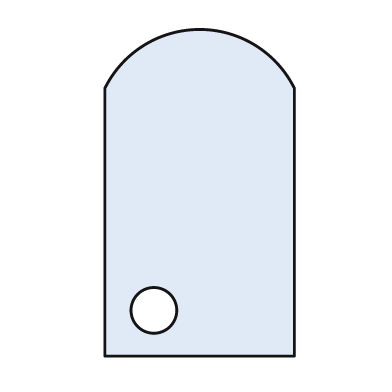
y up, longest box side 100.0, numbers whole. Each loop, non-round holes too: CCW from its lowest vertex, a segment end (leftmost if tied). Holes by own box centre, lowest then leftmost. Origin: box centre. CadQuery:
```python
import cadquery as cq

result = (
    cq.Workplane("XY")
    .moveTo(-29.0, -50.0)
    .lineTo(29.0, -50.0)
    .lineTo(29.0, 32.0)
    .threePointArc((0.0, 50.0), (-29.0, 32.0))
    .close()
    .moveTo(-14.0, -36.0)
    .circle(7.0)
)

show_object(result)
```